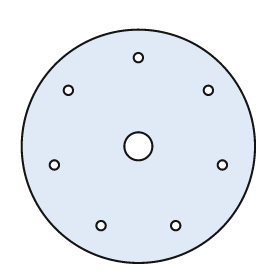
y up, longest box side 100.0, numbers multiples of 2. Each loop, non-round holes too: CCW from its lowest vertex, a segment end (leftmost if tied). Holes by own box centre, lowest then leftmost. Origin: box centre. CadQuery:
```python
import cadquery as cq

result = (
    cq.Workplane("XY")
    .moveTo(0.0, 0.0)
    .circle(50.0)
    .moveTo(-16.0, -34.0)
    .circle(2.0)
    .moveTo(16.0, -34.0)
    .circle(2.0)
    .moveTo(-36.0, -8.0)
    .circle(2.0)
    .moveTo(36.0, -8.0)
    .circle(2.0)
    .moveTo(0.0, 0.0)
    .circle(6.0)
    .moveTo(-30.0, 24.0)
    .circle(2.0)
    .moveTo(30.0, 24.0)
    .circle(2.0)
    .moveTo(0.0, 38.0)
    .circle(2.0)
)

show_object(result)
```